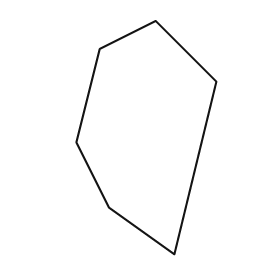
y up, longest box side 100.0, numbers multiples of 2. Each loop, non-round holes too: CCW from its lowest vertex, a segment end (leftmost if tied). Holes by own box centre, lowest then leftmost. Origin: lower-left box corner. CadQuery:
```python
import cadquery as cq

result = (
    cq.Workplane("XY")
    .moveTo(42.0, 0.0)
    .lineTo(60.0, 74.0)
    .lineTo(34.0, 100.0)
    .lineTo(10.0, 88.0)
    .lineTo(0.0, 48.0)
    .lineTo(14.0, 20.0)
    .close()
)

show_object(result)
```